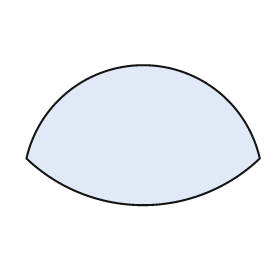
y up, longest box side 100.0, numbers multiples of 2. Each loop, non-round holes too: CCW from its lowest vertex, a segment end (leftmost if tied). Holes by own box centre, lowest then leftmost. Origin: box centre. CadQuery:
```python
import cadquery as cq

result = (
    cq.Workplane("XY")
    .moveTo(-50.0, -10.0)
    .threePointArc((0.0, -30.0), (50.0, -10.0))
    .threePointArc((0.0, 30.0), (-50.0, -10.0))
    .close()
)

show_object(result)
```